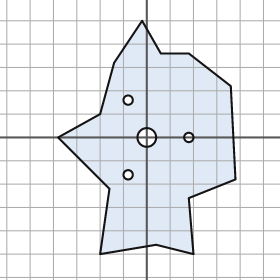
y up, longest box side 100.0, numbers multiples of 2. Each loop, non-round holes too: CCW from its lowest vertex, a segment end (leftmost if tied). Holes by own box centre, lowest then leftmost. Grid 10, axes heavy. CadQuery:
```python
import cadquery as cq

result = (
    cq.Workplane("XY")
    .moveTo(-20.0, -50.0)
    .lineTo(4.0, -46.0)
    .lineTo(20.0, -50.0)
    .lineTo(18.0, -26.0)
    .lineTo(38.0, -18.0)
    .lineTo(36.0, 22.0)
    .lineTo(18.0, 36.0)
    .lineTo(6.0, 36.0)
    .lineTo(-2.0, 50.0)
    .lineTo(-14.0, 32.0)
    .lineTo(-20.0, 10.0)
    .lineTo(-38.0, 0.0)
    .lineTo(-16.0, -22.0)
    .close()
    .moveTo(-8.0, -16.0)
    .circle(2.0)
    .moveTo(0.0, 0.0)
    .circle(4.0)
    .moveTo(18.0, 0.0)
    .circle(2.0)
    .moveTo(-8.0, 16.0)
    .circle(2.0)
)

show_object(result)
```